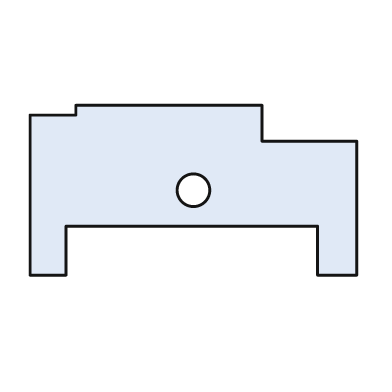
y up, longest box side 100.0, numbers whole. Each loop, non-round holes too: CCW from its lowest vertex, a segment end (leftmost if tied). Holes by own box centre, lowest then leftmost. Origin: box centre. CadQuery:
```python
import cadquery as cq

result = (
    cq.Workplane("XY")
    .moveTo(-50.0, -26.0)
    .lineTo(-39.0, -26.0)
    .lineTo(-39.0, -11.0)
    .lineTo(38.0, -11.0)
    .lineTo(38.0, -26.0)
    .lineTo(50.0, -26.0)
    .lineTo(50.0, 15.0)
    .lineTo(21.0, 15.0)
    .lineTo(21.0, 26.0)
    .lineTo(-36.0, 26.0)
    .lineTo(-36.0, 23.0)
    .lineTo(-50.0, 23.0)
    .close()
    .moveTo(0.0, 0.0)
    .circle(5.0)
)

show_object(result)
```